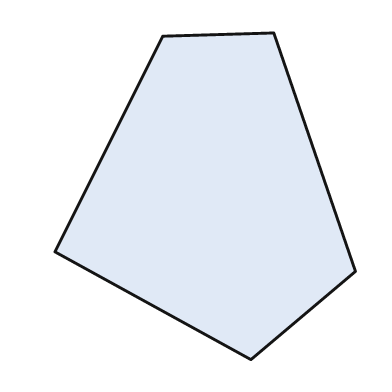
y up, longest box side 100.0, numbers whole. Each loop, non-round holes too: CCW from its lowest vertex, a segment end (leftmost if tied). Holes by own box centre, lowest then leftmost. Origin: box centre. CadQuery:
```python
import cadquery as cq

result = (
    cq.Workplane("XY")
    .moveTo(14.0, -50.0)
    .lineTo(46.0, -23.0)
    .lineTo(21.0, 50.0)
    .lineTo(-13.0, 49.0)
    .lineTo(-46.0, -17.0)
    .close()
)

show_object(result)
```